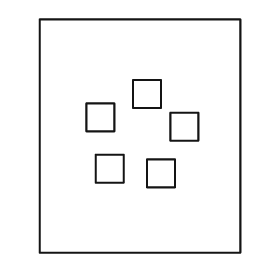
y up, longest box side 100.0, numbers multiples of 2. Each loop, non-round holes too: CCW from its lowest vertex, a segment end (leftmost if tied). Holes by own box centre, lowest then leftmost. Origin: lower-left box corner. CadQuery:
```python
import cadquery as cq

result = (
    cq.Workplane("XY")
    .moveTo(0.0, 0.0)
    .lineTo(86.0, 0.0)
    .lineTo(86.0, 100.0)
    .lineTo(0.0, 100.0)
    .close()
    .moveTo(46.0, 28.0)
    .lineTo(58.0, 28.0)
    .lineTo(58.0, 40.0)
    .lineTo(46.0, 40.0)
    .close()
    .moveTo(24.0, 30.0)
    .lineTo(36.0, 30.0)
    .lineTo(36.0, 42.0)
    .lineTo(24.0, 42.0)
    .close()
    .moveTo(56.0, 48.0)
    .lineTo(68.0, 48.0)
    .lineTo(68.0, 60.0)
    .lineTo(56.0, 60.0)
    .close()
    .moveTo(20.0, 52.0)
    .lineTo(32.0, 52.0)
    .lineTo(32.0, 64.0)
    .lineTo(20.0, 64.0)
    .close()
    .moveTo(40.0, 62.0)
    .lineTo(52.0, 62.0)
    .lineTo(52.0, 74.0)
    .lineTo(40.0, 74.0)
    .close()
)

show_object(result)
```